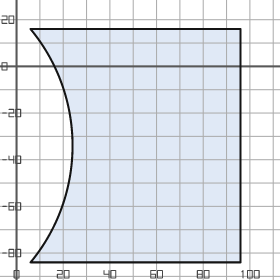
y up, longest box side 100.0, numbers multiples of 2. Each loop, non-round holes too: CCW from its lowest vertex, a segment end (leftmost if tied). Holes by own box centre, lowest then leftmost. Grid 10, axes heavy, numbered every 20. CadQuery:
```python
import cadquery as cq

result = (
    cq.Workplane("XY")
    .moveTo(6.0, -84.0)
    .lineTo(96.0, -84.0)
    .lineTo(96.0, 16.0)
    .lineTo(6.0, 16.0)
    .threePointArc((24.0, -34.0), (6.0, -84.0))
    .close()
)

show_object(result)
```